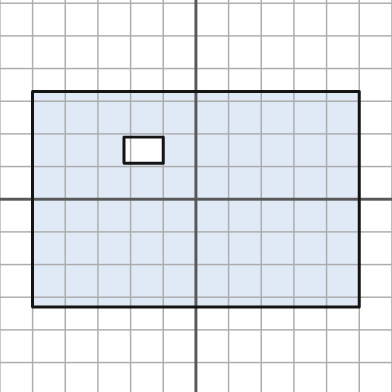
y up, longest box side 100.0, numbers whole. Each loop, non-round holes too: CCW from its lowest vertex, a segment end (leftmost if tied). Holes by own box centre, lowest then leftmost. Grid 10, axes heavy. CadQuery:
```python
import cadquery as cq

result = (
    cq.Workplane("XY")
    .moveTo(-50.0, -33.0)
    .lineTo(50.0, -33.0)
    .lineTo(50.0, 33.0)
    .lineTo(-50.0, 33.0)
    .close()
    .moveTo(-22.0, 11.0)
    .lineTo(-10.0, 11.0)
    .lineTo(-10.0, 19.0)
    .lineTo(-22.0, 19.0)
    .close()
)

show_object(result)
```